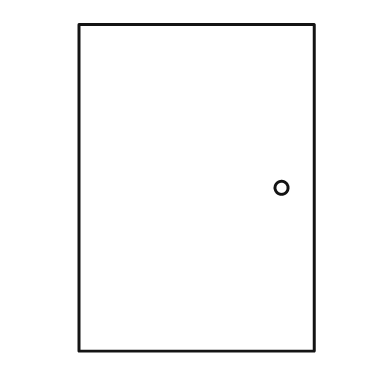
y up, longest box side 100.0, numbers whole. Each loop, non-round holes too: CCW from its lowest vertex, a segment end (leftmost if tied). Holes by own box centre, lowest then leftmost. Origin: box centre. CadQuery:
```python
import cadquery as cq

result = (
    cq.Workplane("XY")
    .moveTo(-36.0, -50.0)
    .lineTo(36.0, -50.0)
    .lineTo(36.0, 50.0)
    .lineTo(-36.0, 50.0)
    .close()
    .moveTo(26.0, 0.0)
    .circle(2.0)
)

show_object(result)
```